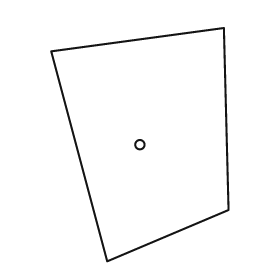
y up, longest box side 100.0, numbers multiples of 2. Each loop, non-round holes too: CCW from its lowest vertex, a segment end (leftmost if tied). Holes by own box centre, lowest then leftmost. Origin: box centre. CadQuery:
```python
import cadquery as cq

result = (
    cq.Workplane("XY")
    .moveTo(-14.0, -50.0)
    .lineTo(38.0, -28.0)
    .lineTo(36.0, 50.0)
    .lineTo(-38.0, 40.0)
    .close()
    .moveTo(0.0, 0.0)
    .circle(2.0)
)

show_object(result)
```